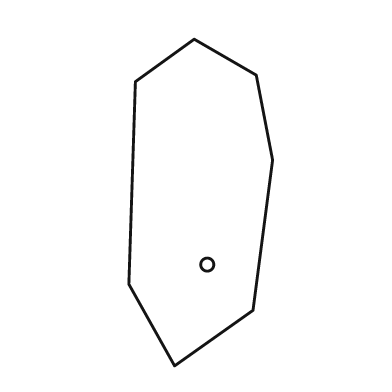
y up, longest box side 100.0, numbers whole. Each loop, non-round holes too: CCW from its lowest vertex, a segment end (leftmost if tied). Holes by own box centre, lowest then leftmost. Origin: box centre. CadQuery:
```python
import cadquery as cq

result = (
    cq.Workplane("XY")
    .moveTo(-8.0, -50.0)
    .lineTo(16.0, -33.0)
    .lineTo(22.0, 13.0)
    .lineTo(17.0, 39.0)
    .lineTo(-2.0, 50.0)
    .lineTo(-20.0, 37.0)
    .lineTo(-22.0, -25.0)
    .close()
    .moveTo(2.0, -19.0)
    .circle(2.0)
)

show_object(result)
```